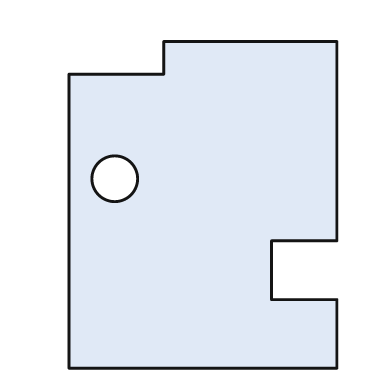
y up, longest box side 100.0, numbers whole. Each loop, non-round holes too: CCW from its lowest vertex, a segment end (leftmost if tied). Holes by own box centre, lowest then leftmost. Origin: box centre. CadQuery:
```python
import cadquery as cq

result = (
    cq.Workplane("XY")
    .moveTo(-41.0, -50.0)
    .lineTo(41.0, -50.0)
    .lineTo(41.0, -29.0)
    .lineTo(21.0, -29.0)
    .lineTo(21.0, -11.0)
    .lineTo(41.0, -11.0)
    .lineTo(41.0, 50.0)
    .lineTo(-12.0, 50.0)
    .lineTo(-12.0, 40.0)
    .lineTo(-41.0, 40.0)
    .close()
    .moveTo(-27.0, 8.0)
    .circle(7.0)
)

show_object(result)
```